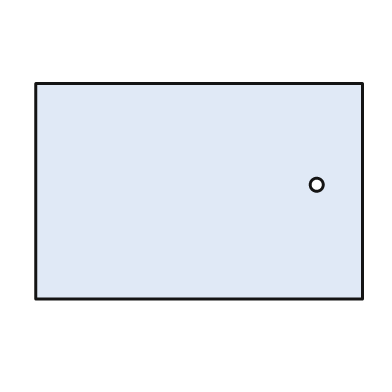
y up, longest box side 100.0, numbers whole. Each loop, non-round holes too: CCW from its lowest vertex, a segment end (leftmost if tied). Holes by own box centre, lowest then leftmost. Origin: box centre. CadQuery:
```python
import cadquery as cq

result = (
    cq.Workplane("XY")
    .moveTo(-50.0, -33.0)
    .lineTo(50.0, -33.0)
    .lineTo(50.0, 33.0)
    .lineTo(-50.0, 33.0)
    .close()
    .moveTo(36.0, 2.0)
    .circle(2.0)
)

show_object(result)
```